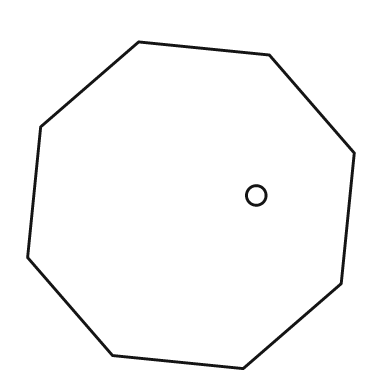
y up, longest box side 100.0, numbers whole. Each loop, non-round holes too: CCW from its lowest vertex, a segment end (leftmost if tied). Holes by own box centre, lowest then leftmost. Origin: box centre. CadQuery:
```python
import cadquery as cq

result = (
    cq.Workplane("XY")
    .moveTo(16.0, -50.0)
    .lineTo(46.0, -24.0)
    .lineTo(50.0, 16.0)
    .lineTo(24.0, 46.0)
    .lineTo(-16.0, 50.0)
    .lineTo(-46.0, 24.0)
    .lineTo(-50.0, -16.0)
    .lineTo(-24.0, -46.0)
    .close()
    .moveTo(20.0, 3.0)
    .circle(3.0)
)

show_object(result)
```